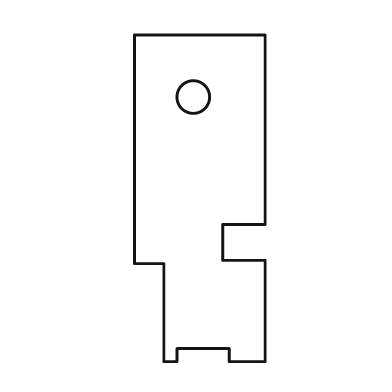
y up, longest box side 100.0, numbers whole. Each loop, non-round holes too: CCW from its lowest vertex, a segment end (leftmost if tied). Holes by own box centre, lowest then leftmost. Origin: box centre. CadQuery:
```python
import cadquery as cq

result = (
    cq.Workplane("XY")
    .moveTo(-11.0, -50.0)
    .lineTo(-7.0, -50.0)
    .lineTo(-7.0, -46.0)
    .lineTo(9.0, -46.0)
    .lineTo(9.0, -50.0)
    .lineTo(20.0, -50.0)
    .lineTo(20.0, -19.0)
    .lineTo(7.0, -19.0)
    .lineTo(7.0, -8.0)
    .lineTo(20.0, -8.0)
    .lineTo(20.0, 50.0)
    .lineTo(-20.0, 50.0)
    .lineTo(-20.0, -20.0)
    .lineTo(-11.0, -20.0)
    .close()
    .moveTo(-2.0, 31.0)
    .circle(5.0)
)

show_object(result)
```